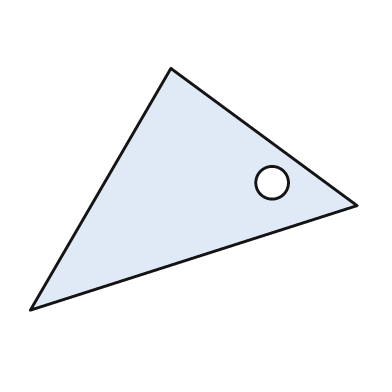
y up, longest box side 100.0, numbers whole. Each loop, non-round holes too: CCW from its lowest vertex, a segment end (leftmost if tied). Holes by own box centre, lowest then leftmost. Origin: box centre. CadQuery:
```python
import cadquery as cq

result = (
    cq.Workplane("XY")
    .moveTo(-50.0, -37.0)
    .lineTo(50.0, -5.0)
    .lineTo(-7.0, 37.0)
    .close()
    .moveTo(24.0, 2.0)
    .circle(5.0)
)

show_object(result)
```